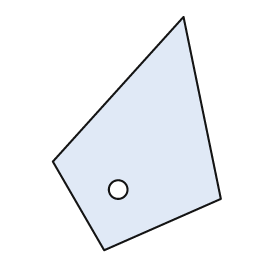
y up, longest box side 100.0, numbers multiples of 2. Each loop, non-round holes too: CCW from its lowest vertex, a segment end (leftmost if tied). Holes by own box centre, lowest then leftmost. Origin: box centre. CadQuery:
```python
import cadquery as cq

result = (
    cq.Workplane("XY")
    .moveTo(-14.0, -50.0)
    .lineTo(36.0, -28.0)
    .lineTo(20.0, 50.0)
    .lineTo(-36.0, -12.0)
    .close()
    .moveTo(-8.0, -24.0)
    .circle(4.0)
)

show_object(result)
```